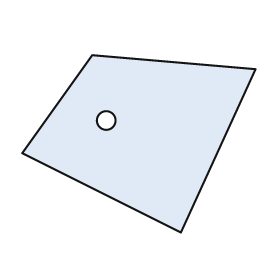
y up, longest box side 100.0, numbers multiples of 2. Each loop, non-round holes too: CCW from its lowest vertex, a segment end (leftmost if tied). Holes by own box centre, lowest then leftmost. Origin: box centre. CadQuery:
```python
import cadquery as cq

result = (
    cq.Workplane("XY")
    .moveTo(18.0, -38.0)
    .lineTo(50.0, 32.0)
    .lineTo(-20.0, 38.0)
    .lineTo(-50.0, -4.0)
    .close()
    .moveTo(-14.0, 10.0)
    .circle(4.0)
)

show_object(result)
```